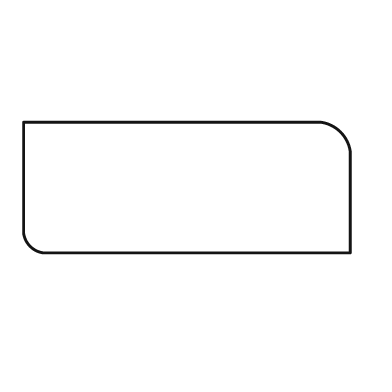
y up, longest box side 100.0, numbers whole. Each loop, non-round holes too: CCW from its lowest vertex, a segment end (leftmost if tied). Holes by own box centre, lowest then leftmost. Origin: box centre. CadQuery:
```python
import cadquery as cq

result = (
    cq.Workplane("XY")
    .moveTo(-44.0, -20.0)
    .lineTo(50.0, -20.0)
    .lineTo(50.0, 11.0)
    .threePointArc((47.0, 17.0), (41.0, 20.0))
    .lineTo(-50.0, 20.0)
    .lineTo(-50.0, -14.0)
    .threePointArc((-48.0, -18.0), (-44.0, -20.0))
    .close()
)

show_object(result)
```